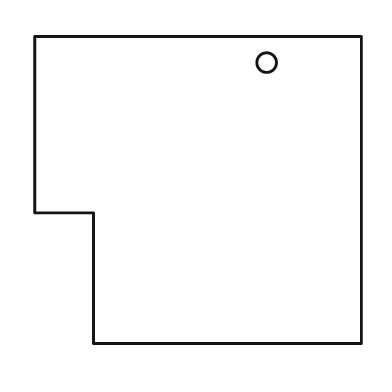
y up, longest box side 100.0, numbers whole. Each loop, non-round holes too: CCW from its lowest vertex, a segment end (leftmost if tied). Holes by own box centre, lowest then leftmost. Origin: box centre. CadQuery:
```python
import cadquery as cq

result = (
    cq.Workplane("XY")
    .moveTo(-32.0, -47.0)
    .lineTo(50.0, -47.0)
    .lineTo(50.0, 47.0)
    .lineTo(-50.0, 47.0)
    .lineTo(-50.0, -7.0)
    .lineTo(-32.0, -7.0)
    .close()
    .moveTo(21.0, 39.0)
    .circle(3.0)
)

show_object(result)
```